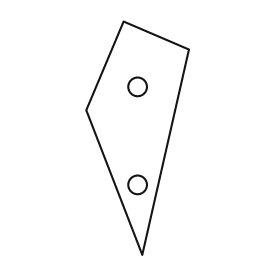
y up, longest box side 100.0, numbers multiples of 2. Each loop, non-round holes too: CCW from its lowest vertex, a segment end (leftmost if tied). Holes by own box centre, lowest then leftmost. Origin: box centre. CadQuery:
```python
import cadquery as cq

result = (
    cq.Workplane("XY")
    .moveTo(2.0, -50.0)
    .lineTo(22.0, 38.0)
    .lineTo(-6.0, 50.0)
    .lineTo(-22.0, 12.0)
    .close()
    .moveTo(0.0, -20.0)
    .circle(4.0)
    .moveTo(0.0, 22.0)
    .circle(4.0)
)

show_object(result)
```